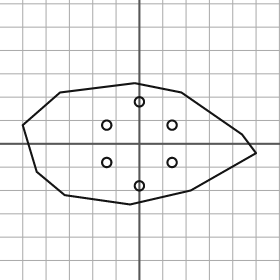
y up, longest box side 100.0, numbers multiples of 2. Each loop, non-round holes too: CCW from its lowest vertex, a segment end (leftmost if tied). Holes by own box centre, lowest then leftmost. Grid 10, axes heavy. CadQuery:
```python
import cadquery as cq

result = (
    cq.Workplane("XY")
    .moveTo(-4.0, -26.0)
    .lineTo(22.0, -20.0)
    .lineTo(50.0, -4.0)
    .lineTo(44.0, 4.0)
    .lineTo(18.0, 22.0)
    .lineTo(-2.0, 26.0)
    .lineTo(-34.0, 22.0)
    .lineTo(-50.0, 8.0)
    .lineTo(-44.0, -12.0)
    .lineTo(-32.0, -22.0)
    .close()
    .moveTo(0.0, -18.0)
    .circle(2.0)
    .moveTo(-14.0, -8.0)
    .circle(2.0)
    .moveTo(14.0, -8.0)
    .circle(2.0)
    .moveTo(-14.0, 8.0)
    .circle(2.0)
    .moveTo(14.0, 8.0)
    .circle(2.0)
    .moveTo(0.0, 18.0)
    .circle(2.0)
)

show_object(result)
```